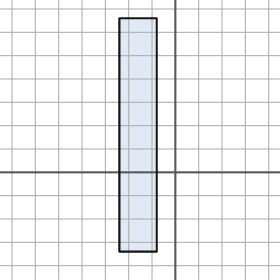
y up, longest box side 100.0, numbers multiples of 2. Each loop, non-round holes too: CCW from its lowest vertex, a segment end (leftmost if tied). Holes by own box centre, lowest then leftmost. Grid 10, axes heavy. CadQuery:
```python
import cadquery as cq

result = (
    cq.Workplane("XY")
    .moveTo(-24.0, -34.0)
    .lineTo(-8.0, -34.0)
    .lineTo(-8.0, 66.0)
    .lineTo(-24.0, 66.0)
    .close()
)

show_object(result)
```